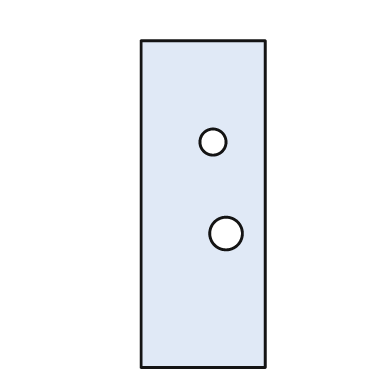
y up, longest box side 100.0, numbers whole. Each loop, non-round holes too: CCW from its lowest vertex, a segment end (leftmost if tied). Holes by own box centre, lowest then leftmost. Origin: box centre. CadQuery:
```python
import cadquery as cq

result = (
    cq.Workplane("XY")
    .moveTo(-19.0, -50.0)
    .lineTo(19.0, -50.0)
    .lineTo(19.0, 50.0)
    .lineTo(-19.0, 50.0)
    .close()
    .moveTo(7.0, -9.0)
    .circle(5.0)
    .moveTo(3.0, 19.0)
    .circle(4.0)
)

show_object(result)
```